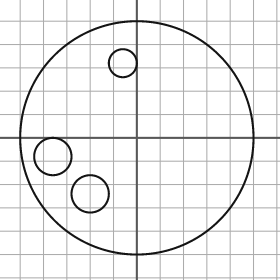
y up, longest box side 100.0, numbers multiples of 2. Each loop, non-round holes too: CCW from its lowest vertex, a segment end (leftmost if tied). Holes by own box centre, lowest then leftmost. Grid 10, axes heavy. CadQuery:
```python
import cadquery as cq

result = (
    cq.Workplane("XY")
    .moveTo(0.0, 0.0)
    .circle(50.0)
    .moveTo(-20.0, -24.0)
    .circle(8.0)
    .moveTo(-36.0, -8.0)
    .circle(8.0)
    .moveTo(-6.0, 32.0)
    .circle(6.0)
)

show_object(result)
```